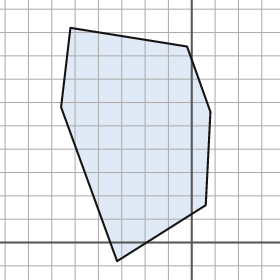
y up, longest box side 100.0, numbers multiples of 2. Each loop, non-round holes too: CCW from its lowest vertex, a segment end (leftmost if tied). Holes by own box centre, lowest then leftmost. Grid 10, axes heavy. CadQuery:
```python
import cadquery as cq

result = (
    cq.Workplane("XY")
    .moveTo(-32.0, -8.0)
    .lineTo(6.0, 16.0)
    .lineTo(8.0, 56.0)
    .lineTo(-2.0, 84.0)
    .lineTo(-52.0, 92.0)
    .lineTo(-56.0, 58.0)
    .close()
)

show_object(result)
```